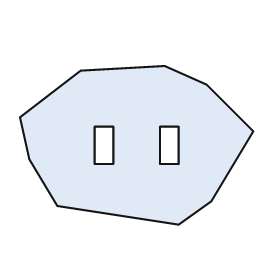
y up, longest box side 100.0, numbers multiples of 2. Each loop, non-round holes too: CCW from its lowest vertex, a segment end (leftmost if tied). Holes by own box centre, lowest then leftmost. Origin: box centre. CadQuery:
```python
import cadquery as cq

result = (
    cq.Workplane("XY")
    .moveTo(18.0, -34.0)
    .lineTo(32.0, -24.0)
    .lineTo(50.0, 6.0)
    .lineTo(30.0, 26.0)
    .lineTo(12.0, 34.0)
    .lineTo(-24.0, 32.0)
    .lineTo(-50.0, 12.0)
    .lineTo(-46.0, -6.0)
    .lineTo(-34.0, -26.0)
    .close()
    .moveTo(-18.0, -8.0)
    .lineTo(-10.0, -8.0)
    .lineTo(-10.0, 8.0)
    .lineTo(-18.0, 8.0)
    .close()
    .moveTo(10.0, -8.0)
    .lineTo(18.0, -8.0)
    .lineTo(18.0, 8.0)
    .lineTo(10.0, 8.0)
    .close()
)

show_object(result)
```